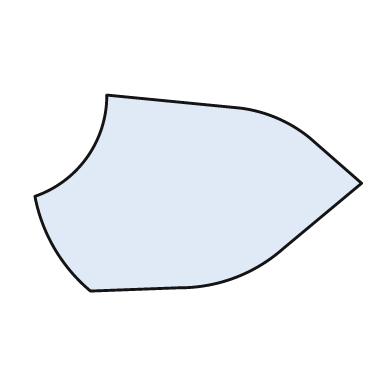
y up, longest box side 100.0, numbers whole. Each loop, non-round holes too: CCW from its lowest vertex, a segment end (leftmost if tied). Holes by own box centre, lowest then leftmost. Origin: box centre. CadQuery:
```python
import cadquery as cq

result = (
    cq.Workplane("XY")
    .moveTo(-33.0, -30.0)
    .lineTo(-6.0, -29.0)
    .threePointArc((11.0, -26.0), (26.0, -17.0))
    .lineTo(50.0, 3.0)
    .lineTo(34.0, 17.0)
    .threePointArc((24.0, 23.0), (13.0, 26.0))
    .lineTo(-28.0, 30.0)
    .threePointArc((-34.0, 11.0), (-50.0, -1.0))
    .threePointArc((-44.0, -17.0), (-33.0, -30.0))
    .close()
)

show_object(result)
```